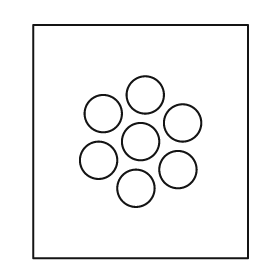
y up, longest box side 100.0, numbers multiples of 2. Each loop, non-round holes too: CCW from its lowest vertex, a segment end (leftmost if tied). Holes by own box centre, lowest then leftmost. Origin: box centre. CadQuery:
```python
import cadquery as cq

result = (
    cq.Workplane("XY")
    .moveTo(-46.0, -50.0)
    .lineTo(46.0, -50.0)
    .lineTo(46.0, 50.0)
    .lineTo(-46.0, 50.0)
    .close()
    .moveTo(-2.0, -20.0)
    .circle(8.0)
    .moveTo(16.0, -12.0)
    .circle(8.0)
    .moveTo(-18.0, -8.0)
    .circle(8.0)
    .moveTo(0.0, 0.0)
    .circle(8.0)
    .moveTo(18.0, 8.0)
    .circle(8.0)
    .moveTo(-16.0, 12.0)
    .circle(8.0)
    .moveTo(2.0, 20.0)
    .circle(8.0)
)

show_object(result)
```